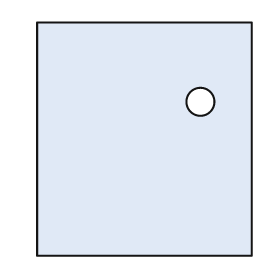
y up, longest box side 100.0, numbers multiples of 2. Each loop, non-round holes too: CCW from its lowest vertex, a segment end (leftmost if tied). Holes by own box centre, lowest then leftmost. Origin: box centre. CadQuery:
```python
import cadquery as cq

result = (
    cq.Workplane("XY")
    .moveTo(-46.0, -50.0)
    .lineTo(46.0, -50.0)
    .lineTo(46.0, 50.0)
    .lineTo(-46.0, 50.0)
    .close()
    .moveTo(24.0, 16.0)
    .circle(6.0)
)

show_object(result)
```